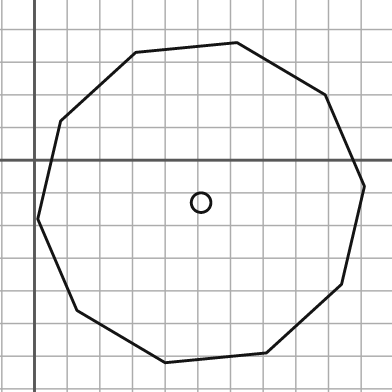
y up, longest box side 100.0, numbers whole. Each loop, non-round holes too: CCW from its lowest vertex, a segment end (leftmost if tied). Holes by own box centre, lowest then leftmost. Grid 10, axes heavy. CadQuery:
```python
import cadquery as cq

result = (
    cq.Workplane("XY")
    .moveTo(40.0, -62.0)
    .lineTo(71.0, -59.0)
    .lineTo(94.0, -38.0)
    .lineTo(101.0, -8.0)
    .lineTo(89.0, 20.0)
    .lineTo(62.0, 36.0)
    .lineTo(31.0, 33.0)
    .lineTo(8.0, 12.0)
    .lineTo(1.0, -18.0)
    .lineTo(13.0, -46.0)
    .close()
    .moveTo(51.0, -13.0)
    .circle(3.0)
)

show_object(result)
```